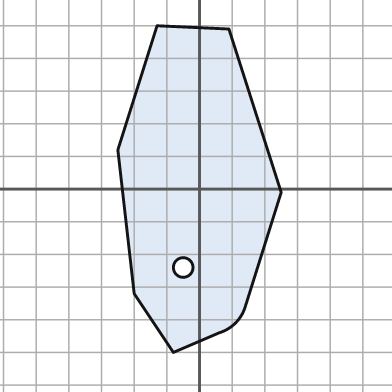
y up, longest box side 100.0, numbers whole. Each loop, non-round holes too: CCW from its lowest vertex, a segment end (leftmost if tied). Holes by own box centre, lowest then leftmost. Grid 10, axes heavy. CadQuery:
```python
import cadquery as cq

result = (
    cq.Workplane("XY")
    .moveTo(-8.0, -50.0)
    .lineTo(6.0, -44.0)
    .threePointArc((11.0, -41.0), (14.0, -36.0))
    .lineTo(25.0, -1.0)
    .lineTo(9.0, 49.0)
    .lineTo(-13.0, 50.0)
    .lineTo(-25.0, 12.0)
    .lineTo(-20.0, -32.0)
    .close()
    .moveTo(-5.0, -24.0)
    .circle(3.0)
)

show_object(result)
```